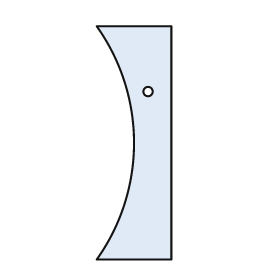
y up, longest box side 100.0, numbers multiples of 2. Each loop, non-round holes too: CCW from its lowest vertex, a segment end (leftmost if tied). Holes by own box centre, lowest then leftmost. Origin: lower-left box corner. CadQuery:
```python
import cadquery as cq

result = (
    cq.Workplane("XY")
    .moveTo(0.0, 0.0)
    .lineTo(32.0, 0.0)
    .lineTo(32.0, 100.0)
    .lineTo(0.0, 100.0)
    .threePointArc((16.0, 50.0), (0.0, 0.0))
    .close()
    .moveTo(22.0, 72.0)
    .circle(2.0)
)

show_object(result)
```